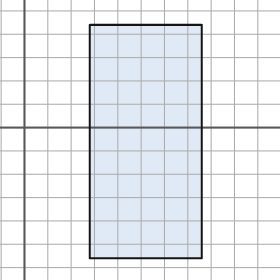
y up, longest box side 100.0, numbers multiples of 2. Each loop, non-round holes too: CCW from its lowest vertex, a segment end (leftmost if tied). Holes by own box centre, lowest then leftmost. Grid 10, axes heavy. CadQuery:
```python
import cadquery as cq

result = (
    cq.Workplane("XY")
    .moveTo(28.0, -56.0)
    .lineTo(76.0, -56.0)
    .lineTo(76.0, 44.0)
    .lineTo(28.0, 44.0)
    .close()
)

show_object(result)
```